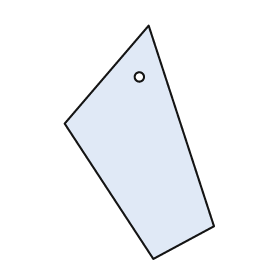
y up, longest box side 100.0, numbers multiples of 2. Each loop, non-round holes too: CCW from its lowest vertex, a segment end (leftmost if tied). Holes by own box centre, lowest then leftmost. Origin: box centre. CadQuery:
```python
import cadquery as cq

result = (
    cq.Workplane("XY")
    .moveTo(6.0, -50.0)
    .lineTo(32.0, -36.0)
    .lineTo(4.0, 50.0)
    .lineTo(-32.0, 8.0)
    .close()
    .moveTo(0.0, 28.0)
    .circle(2.0)
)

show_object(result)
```